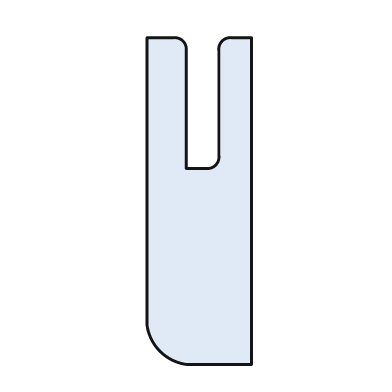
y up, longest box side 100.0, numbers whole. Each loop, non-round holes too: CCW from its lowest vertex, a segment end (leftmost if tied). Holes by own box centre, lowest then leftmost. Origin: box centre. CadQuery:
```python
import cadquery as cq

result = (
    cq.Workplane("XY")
    .moveTo(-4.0, -50.0)
    .lineTo(16.0, -50.0)
    .lineTo(16.0, 50.0)
    .lineTo(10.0, 50.0)
    .threePointArc((7.0, 49.0), (6.0, 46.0))
    .lineTo(6.0, 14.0)
    .threePointArc((5.0, 11.0), (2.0, 10.0))
    .lineTo(-4.0, 10.0)
    .lineTo(-4.0, 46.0)
    .threePointArc((-5.0, 49.0), (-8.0, 50.0))
    .lineTo(-16.0, 50.0)
    .lineTo(-16.0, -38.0)
    .threePointArc((-12.0, -46.0), (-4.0, -50.0))
    .close()
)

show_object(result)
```